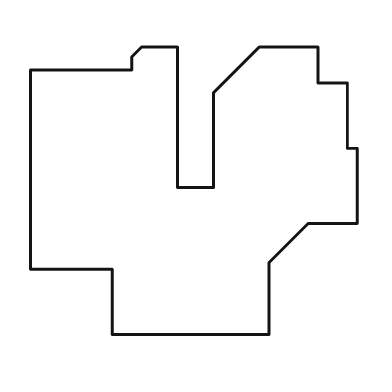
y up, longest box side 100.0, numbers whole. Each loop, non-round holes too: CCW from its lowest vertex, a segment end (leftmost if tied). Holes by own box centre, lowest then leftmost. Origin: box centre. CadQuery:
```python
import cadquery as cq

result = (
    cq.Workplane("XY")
    .moveTo(-25.0, -44.0)
    .lineTo(23.0, -44.0)
    .lineTo(23.0, -22.0)
    .lineTo(35.0, -10.0)
    .lineTo(50.0, -10.0)
    .lineTo(50.0, 13.0)
    .lineTo(47.0, 13.0)
    .lineTo(47.0, 33.0)
    .lineTo(38.0, 33.0)
    .lineTo(38.0, 44.0)
    .lineTo(20.0, 44.0)
    .lineTo(6.0, 30.0)
    .lineTo(6.0, 1.0)
    .lineTo(-5.0, 1.0)
    .lineTo(-5.0, 44.0)
    .lineTo(-16.0, 44.0)
    .lineTo(-19.0, 41.0)
    .lineTo(-19.0, 37.0)
    .lineTo(-50.0, 37.0)
    .lineTo(-50.0, -24.0)
    .lineTo(-25.0, -24.0)
    .close()
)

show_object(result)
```